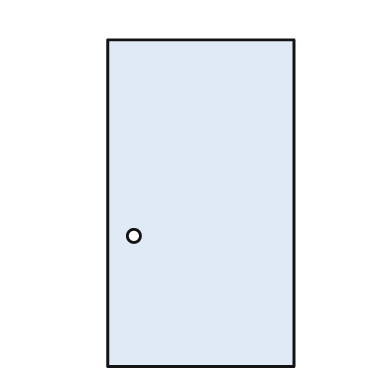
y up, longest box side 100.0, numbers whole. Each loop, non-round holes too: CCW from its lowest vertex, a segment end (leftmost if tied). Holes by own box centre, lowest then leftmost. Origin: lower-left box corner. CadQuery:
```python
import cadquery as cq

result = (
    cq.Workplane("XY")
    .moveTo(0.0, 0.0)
    .lineTo(57.0, 0.0)
    .lineTo(57.0, 100.0)
    .lineTo(0.0, 100.0)
    .close()
    .moveTo(8.0, 40.0)
    .circle(2.0)
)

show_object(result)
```